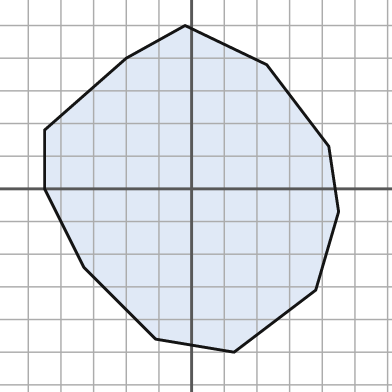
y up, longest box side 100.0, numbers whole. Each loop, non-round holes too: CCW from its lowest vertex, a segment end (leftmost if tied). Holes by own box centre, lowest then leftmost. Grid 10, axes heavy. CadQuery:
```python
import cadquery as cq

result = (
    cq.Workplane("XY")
    .moveTo(13.0, -50.0)
    .lineTo(38.0, -31.0)
    .lineTo(45.0, -7.0)
    .lineTo(42.0, 13.0)
    .lineTo(23.0, 38.0)
    .lineTo(-2.0, 50.0)
    .lineTo(-20.0, 40.0)
    .lineTo(-45.0, 18.0)
    .lineTo(-45.0, 0.0)
    .lineTo(-33.0, -24.0)
    .lineTo(-11.0, -46.0)
    .close()
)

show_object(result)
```